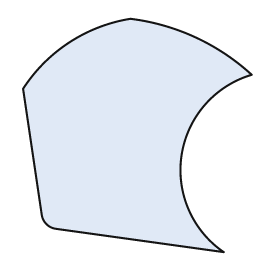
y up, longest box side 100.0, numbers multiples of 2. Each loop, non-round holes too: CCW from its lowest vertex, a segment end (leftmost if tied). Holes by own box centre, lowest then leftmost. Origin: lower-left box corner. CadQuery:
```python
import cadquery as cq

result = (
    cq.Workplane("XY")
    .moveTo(86.0, 0.0)
    .threePointArc((68.0, 42.0), (98.0, 76.0))
    .threePointArc((74.0, 92.0), (46.0, 100.0))
    .threePointArc((20.0, 90.0), (0.0, 70.0))
    .lineTo(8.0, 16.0)
    .threePointArc((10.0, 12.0), (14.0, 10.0))
    .close()
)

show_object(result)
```